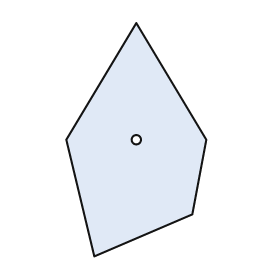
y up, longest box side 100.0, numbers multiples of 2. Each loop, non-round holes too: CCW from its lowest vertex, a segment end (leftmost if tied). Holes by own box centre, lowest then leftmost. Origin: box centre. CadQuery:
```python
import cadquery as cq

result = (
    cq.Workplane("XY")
    .moveTo(-18.0, -50.0)
    .lineTo(24.0, -32.0)
    .lineTo(30.0, 0.0)
    .lineTo(0.0, 50.0)
    .lineTo(-30.0, 0.0)
    .close()
    .moveTo(0.0, 0.0)
    .circle(2.0)
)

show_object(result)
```